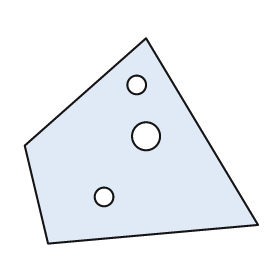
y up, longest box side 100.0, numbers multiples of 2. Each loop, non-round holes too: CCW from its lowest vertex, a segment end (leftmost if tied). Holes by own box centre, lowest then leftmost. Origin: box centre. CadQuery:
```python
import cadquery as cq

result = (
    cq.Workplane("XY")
    .moveTo(-40.0, -44.0)
    .lineTo(50.0, -36.0)
    .lineTo(2.0, 44.0)
    .lineTo(-50.0, -2.0)
    .close()
    .moveTo(-16.0, -24.0)
    .circle(4.0)
    .moveTo(2.0, 2.0)
    .circle(6.0)
    .moveTo(-2.0, 24.0)
    .circle(4.0)
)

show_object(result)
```